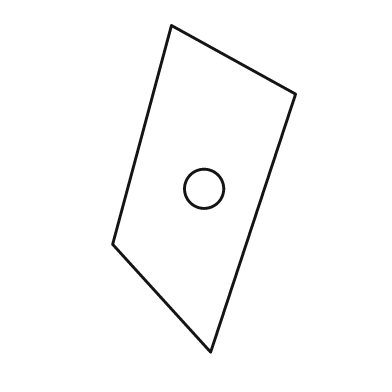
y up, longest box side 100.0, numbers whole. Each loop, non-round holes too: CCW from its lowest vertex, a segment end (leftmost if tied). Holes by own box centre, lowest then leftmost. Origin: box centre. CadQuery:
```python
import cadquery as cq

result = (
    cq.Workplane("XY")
    .moveTo(2.0, -50.0)
    .lineTo(28.0, 29.0)
    .lineTo(-10.0, 50.0)
    .lineTo(-28.0, -17.0)
    .close()
    .moveTo(0.0, 0.0)
    .circle(6.0)
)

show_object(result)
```